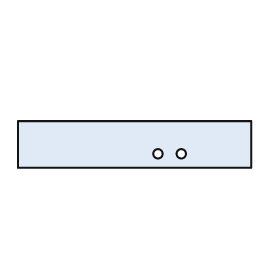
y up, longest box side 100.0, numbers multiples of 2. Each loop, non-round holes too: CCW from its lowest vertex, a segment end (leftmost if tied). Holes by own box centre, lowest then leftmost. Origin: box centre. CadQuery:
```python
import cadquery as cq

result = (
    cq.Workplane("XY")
    .moveTo(-50.0, -10.0)
    .lineTo(50.0, -10.0)
    .lineTo(50.0, 10.0)
    .lineTo(-50.0, 10.0)
    .close()
    .moveTo(10.0, -4.0)
    .circle(2.0)
    .moveTo(20.0, -4.0)
    .circle(2.0)
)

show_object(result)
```